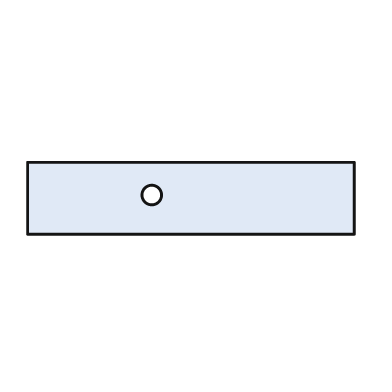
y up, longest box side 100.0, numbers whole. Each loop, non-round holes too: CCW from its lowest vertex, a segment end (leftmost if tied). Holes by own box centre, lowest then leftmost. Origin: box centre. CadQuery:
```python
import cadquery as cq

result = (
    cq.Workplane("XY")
    .moveTo(-50.0, -11.0)
    .lineTo(50.0, -11.0)
    .lineTo(50.0, 11.0)
    .lineTo(-50.0, 11.0)
    .close()
    .moveTo(-12.0, 1.0)
    .circle(3.0)
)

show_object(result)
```